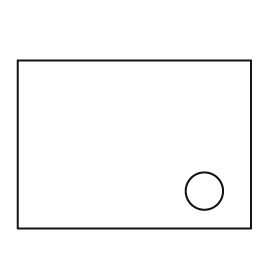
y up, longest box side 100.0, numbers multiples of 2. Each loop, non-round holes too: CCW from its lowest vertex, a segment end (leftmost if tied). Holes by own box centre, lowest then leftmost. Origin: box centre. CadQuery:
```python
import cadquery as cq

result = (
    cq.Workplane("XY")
    .moveTo(-50.0, -36.0)
    .lineTo(50.0, -36.0)
    .lineTo(50.0, 36.0)
    .lineTo(-50.0, 36.0)
    .close()
    .moveTo(30.0, -20.0)
    .circle(8.0)
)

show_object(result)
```